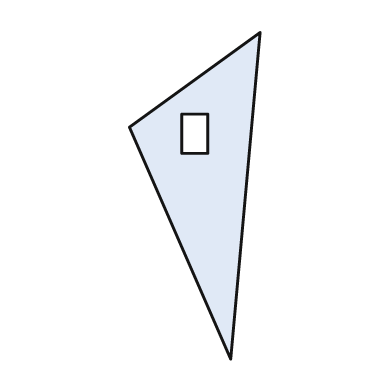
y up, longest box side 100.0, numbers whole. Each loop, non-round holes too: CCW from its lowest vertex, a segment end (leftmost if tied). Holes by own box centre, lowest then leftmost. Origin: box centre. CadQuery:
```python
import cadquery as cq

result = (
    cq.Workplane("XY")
    .moveTo(11.0, -50.0)
    .lineTo(20.0, 50.0)
    .lineTo(-20.0, 21.0)
    .close()
    .moveTo(-4.0, 13.0)
    .lineTo(4.0, 13.0)
    .lineTo(4.0, 25.0)
    .lineTo(-4.0, 25.0)
    .close()
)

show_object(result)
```